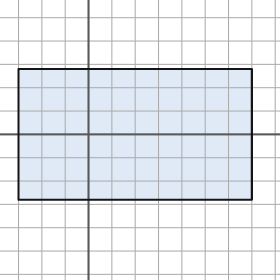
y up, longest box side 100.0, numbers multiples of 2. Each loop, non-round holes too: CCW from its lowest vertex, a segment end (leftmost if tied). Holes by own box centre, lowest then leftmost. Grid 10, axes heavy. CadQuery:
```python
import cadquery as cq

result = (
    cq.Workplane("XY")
    .moveTo(-30.0, -28.0)
    .lineTo(70.0, -28.0)
    .lineTo(70.0, 28.0)
    .lineTo(-30.0, 28.0)
    .close()
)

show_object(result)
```